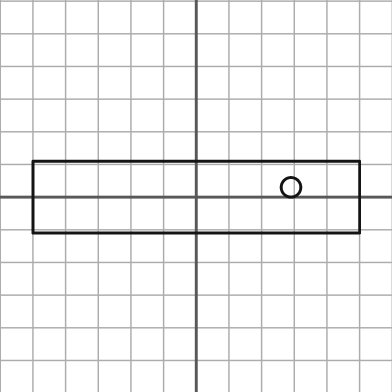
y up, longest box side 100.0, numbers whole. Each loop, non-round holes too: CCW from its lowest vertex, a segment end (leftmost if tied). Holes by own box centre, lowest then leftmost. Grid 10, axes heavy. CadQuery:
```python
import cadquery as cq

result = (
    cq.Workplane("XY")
    .moveTo(-50.0, -11.0)
    .lineTo(50.0, -11.0)
    .lineTo(50.0, 11.0)
    .lineTo(-50.0, 11.0)
    .close()
    .moveTo(29.0, 3.0)
    .circle(3.0)
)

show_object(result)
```